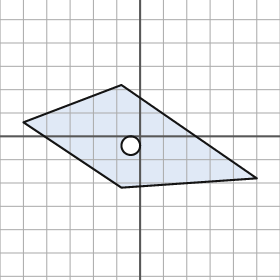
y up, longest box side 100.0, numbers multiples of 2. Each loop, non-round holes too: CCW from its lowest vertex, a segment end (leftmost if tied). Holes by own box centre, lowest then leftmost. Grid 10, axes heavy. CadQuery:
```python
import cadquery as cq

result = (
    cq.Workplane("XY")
    .moveTo(-8.0, -22.0)
    .lineTo(50.0, -18.0)
    .lineTo(-8.0, 22.0)
    .lineTo(-50.0, 6.0)
    .close()
    .moveTo(-4.0, -4.0)
    .circle(4.0)
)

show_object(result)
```